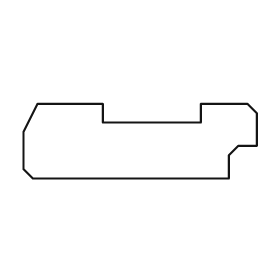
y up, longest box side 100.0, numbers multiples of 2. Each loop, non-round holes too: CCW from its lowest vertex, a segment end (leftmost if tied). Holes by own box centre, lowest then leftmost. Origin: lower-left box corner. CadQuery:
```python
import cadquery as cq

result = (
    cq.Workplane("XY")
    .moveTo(4.0, 0.0)
    .lineTo(88.0, 0.0)
    .lineTo(88.0, 10.0)
    .lineTo(92.0, 14.0)
    .lineTo(100.0, 14.0)
    .lineTo(100.0, 28.0)
    .lineTo(96.0, 32.0)
    .lineTo(76.0, 32.0)
    .lineTo(76.0, 24.0)
    .lineTo(34.0, 24.0)
    .lineTo(34.0, 32.0)
    .lineTo(6.0, 32.0)
    .lineTo(0.0, 20.0)
    .lineTo(0.0, 4.0)
    .close()
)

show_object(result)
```